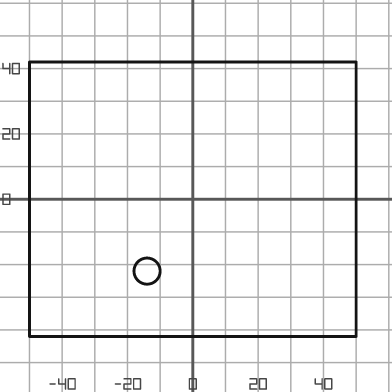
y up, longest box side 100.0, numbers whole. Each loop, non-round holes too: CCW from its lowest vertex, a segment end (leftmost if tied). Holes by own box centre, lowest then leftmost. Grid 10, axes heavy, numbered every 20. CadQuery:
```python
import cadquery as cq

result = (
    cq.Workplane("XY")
    .moveTo(-50.0, -42.0)
    .lineTo(50.0, -42.0)
    .lineTo(50.0, 42.0)
    .lineTo(-50.0, 42.0)
    .close()
    .moveTo(-14.0, -22.0)
    .circle(4.0)
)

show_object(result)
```